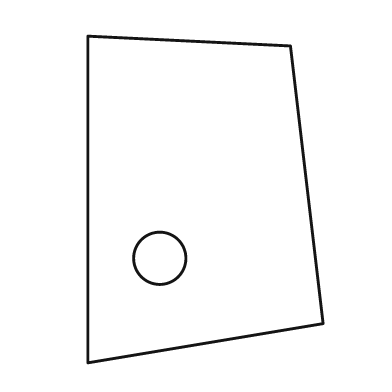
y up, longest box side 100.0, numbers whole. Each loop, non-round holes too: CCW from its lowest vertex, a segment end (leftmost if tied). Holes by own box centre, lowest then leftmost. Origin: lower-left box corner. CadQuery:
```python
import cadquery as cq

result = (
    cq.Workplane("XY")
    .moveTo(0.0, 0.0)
    .lineTo(72.0, 12.0)
    .lineTo(62.0, 97.0)
    .lineTo(0.0, 100.0)
    .close()
    .moveTo(22.0, 32.0)
    .circle(8.0)
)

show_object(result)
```